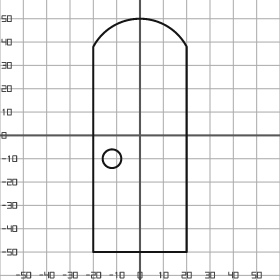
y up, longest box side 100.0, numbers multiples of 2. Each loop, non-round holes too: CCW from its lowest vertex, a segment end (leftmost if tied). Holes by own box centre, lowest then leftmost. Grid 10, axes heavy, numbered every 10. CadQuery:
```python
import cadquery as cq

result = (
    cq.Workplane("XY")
    .moveTo(-20.0, -50.0)
    .lineTo(20.0, -50.0)
    .lineTo(20.0, 38.0)
    .threePointArc((0.0, 50.0), (-20.0, 38.0))
    .close()
    .moveTo(-12.0, -10.0)
    .circle(4.0)
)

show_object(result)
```